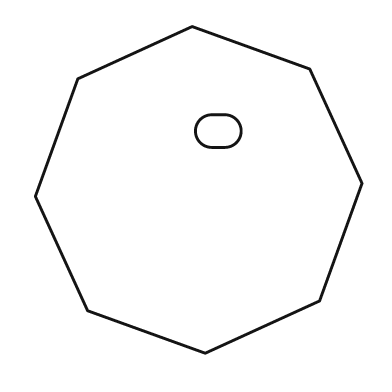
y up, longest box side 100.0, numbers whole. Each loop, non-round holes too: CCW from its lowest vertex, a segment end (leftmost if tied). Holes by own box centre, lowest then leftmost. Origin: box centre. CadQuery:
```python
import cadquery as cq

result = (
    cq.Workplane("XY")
    .moveTo(2.0, -50.0)
    .lineTo(37.0, -34.0)
    .lineTo(50.0, 2.0)
    .lineTo(34.0, 37.0)
    .lineTo(-2.0, 50.0)
    .lineTo(-37.0, 34.0)
    .lineTo(-50.0, -2.0)
    .lineTo(-34.0, -37.0)
    .close()
    .moveTo(4.0, 13.0)
    .lineTo(8.0, 13.0)
    .threePointArc((13.0, 18.0), (8.0, 23.0))
    .lineTo(4.0, 23.0)
    .threePointArc((-1.0, 18.0), (4.0, 13.0))
    .close()
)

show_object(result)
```